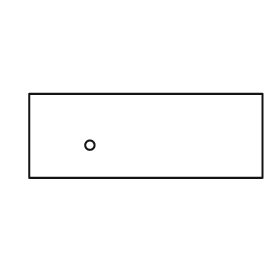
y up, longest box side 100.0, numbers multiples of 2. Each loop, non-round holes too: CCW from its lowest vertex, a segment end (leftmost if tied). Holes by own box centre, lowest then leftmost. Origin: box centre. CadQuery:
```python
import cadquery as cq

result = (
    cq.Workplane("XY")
    .moveTo(-50.0, -18.0)
    .lineTo(50.0, -18.0)
    .lineTo(50.0, 18.0)
    .lineTo(-50.0, 18.0)
    .close()
    .moveTo(-24.0, -4.0)
    .circle(2.0)
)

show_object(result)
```